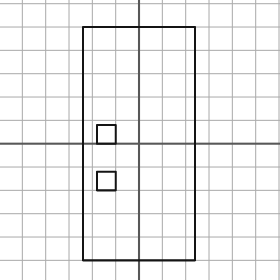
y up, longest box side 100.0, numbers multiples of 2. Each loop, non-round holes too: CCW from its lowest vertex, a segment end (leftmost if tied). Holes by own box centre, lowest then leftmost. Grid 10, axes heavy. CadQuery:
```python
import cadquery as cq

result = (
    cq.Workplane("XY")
    .moveTo(-24.0, -50.0)
    .lineTo(24.0, -50.0)
    .lineTo(24.0, 50.0)
    .lineTo(-24.0, 50.0)
    .close()
    .moveTo(-18.0, -20.0)
    .lineTo(-10.0, -20.0)
    .lineTo(-10.0, -12.0)
    .lineTo(-18.0, -12.0)
    .close()
    .moveTo(-18.0, 0.0)
    .lineTo(-10.0, 0.0)
    .lineTo(-10.0, 8.0)
    .lineTo(-18.0, 8.0)
    .close()
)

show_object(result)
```